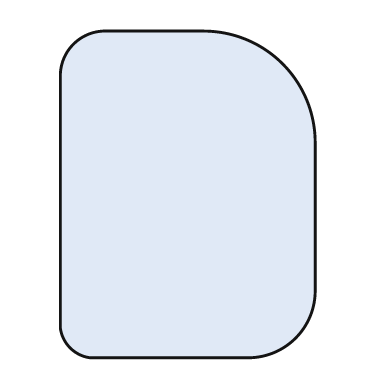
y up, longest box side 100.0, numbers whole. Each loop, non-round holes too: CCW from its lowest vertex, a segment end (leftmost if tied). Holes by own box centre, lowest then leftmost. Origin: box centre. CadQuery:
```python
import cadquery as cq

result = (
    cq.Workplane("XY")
    .moveTo(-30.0, -50.0)
    .lineTo(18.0, -50.0)
    .threePointArc((33.0, -44.0), (39.0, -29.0))
    .lineTo(39.0, 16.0)
    .threePointArc((29.0, 40.0), (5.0, 50.0))
    .lineTo(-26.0, 50.0)
    .threePointArc((-35.0, 46.0), (-39.0, 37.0))
    .lineTo(-39.0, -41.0)
    .threePointArc((-36.0, -47.0), (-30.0, -50.0))
    .close()
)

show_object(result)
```